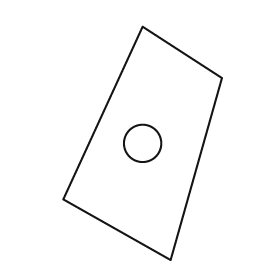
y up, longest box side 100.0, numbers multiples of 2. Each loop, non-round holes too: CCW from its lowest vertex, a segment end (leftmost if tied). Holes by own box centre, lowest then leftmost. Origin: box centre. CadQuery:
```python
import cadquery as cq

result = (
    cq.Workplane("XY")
    .moveTo(12.0, -50.0)
    .lineTo(34.0, 28.0)
    .lineTo(0.0, 50.0)
    .lineTo(-34.0, -24.0)
    .close()
    .moveTo(0.0, 0.0)
    .circle(8.0)
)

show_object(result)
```